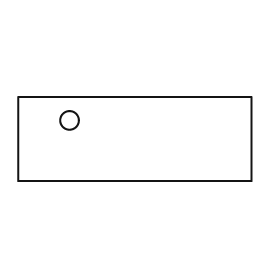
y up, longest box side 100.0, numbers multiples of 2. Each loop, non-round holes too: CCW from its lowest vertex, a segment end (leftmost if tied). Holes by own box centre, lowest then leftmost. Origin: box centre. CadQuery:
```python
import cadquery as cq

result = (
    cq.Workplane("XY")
    .moveTo(-50.0, -18.0)
    .lineTo(50.0, -18.0)
    .lineTo(50.0, 18.0)
    .lineTo(-50.0, 18.0)
    .close()
    .moveTo(-28.0, 8.0)
    .circle(4.0)
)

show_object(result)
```